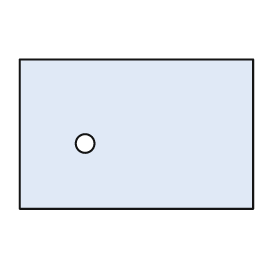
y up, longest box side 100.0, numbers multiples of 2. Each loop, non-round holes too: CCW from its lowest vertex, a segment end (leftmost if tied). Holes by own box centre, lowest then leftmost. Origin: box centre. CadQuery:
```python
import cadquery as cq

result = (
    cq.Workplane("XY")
    .moveTo(-50.0, -32.0)
    .lineTo(50.0, -32.0)
    .lineTo(50.0, 32.0)
    .lineTo(-50.0, 32.0)
    .close()
    .moveTo(-22.0, -4.0)
    .circle(4.0)
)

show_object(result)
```